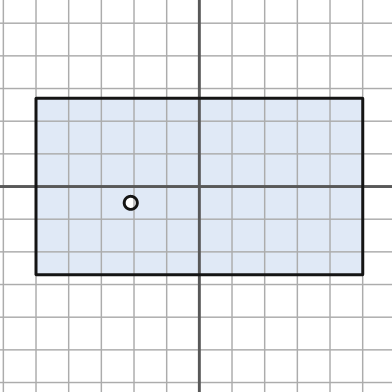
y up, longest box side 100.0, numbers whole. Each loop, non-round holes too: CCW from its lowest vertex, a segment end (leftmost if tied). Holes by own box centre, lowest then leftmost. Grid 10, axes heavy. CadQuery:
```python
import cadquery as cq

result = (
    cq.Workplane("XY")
    .moveTo(-50.0, -27.0)
    .lineTo(50.0, -27.0)
    .lineTo(50.0, 27.0)
    .lineTo(-50.0, 27.0)
    .close()
    .moveTo(-21.0, -5.0)
    .circle(2.0)
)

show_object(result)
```